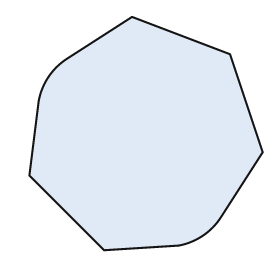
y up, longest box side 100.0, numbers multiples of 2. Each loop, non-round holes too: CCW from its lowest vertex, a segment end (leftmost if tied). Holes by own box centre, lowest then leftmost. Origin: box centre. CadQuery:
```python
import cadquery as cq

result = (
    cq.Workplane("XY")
    .moveTo(-18.0, -50.0)
    .lineTo(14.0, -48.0)
    .threePointArc((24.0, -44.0), (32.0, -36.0))
    .lineTo(50.0, -8.0)
    .lineTo(36.0, 34.0)
    .lineTo(-6.0, 50.0)
    .lineTo(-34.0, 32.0)
    .threePointArc((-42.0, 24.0), (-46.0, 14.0))
    .lineTo(-50.0, -18.0)
    .close()
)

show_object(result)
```